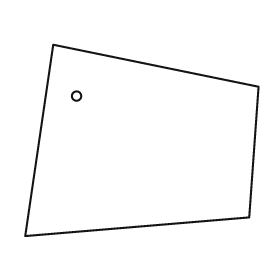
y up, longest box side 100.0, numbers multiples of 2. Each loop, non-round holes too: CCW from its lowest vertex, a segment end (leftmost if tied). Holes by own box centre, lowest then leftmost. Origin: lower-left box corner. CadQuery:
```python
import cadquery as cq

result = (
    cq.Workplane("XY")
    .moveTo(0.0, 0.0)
    .lineTo(96.0, 8.0)
    .lineTo(100.0, 64.0)
    .lineTo(12.0, 82.0)
    .close()
    .moveTo(22.0, 60.0)
    .circle(2.0)
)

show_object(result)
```